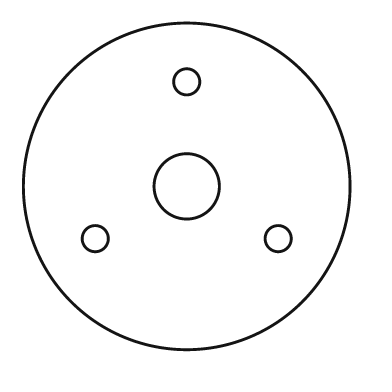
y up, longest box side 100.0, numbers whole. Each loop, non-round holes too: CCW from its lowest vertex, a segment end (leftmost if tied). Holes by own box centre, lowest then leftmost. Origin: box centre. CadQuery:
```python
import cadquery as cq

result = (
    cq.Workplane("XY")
    .moveTo(0.0, 0.0)
    .circle(50.0)
    .moveTo(-28.0, -16.0)
    .circle(4.0)
    .moveTo(28.0, -16.0)
    .circle(4.0)
    .moveTo(0.0, 0.0)
    .circle(10.0)
    .moveTo(0.0, 32.0)
    .circle(4.0)
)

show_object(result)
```